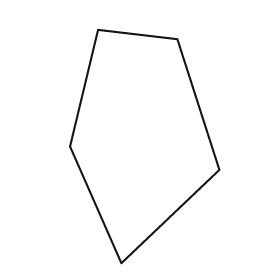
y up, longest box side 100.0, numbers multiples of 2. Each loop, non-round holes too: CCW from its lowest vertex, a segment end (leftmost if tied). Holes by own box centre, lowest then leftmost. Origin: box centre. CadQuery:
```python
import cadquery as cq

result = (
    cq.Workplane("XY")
    .moveTo(-10.0, -50.0)
    .lineTo(32.0, -10.0)
    .lineTo(14.0, 46.0)
    .lineTo(-20.0, 50.0)
    .lineTo(-32.0, 0.0)
    .close()
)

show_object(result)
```